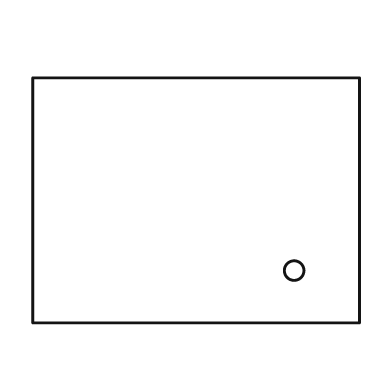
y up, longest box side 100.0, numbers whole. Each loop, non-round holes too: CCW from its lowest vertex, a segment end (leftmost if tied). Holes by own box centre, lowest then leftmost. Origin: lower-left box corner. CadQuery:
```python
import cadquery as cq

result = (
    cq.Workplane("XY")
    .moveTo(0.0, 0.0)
    .lineTo(100.0, 0.0)
    .lineTo(100.0, 75.0)
    .lineTo(0.0, 75.0)
    .close()
    .moveTo(80.0, 16.0)
    .circle(3.0)
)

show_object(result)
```